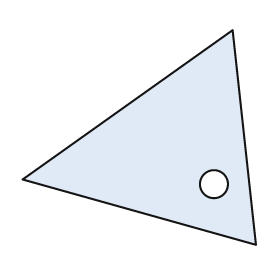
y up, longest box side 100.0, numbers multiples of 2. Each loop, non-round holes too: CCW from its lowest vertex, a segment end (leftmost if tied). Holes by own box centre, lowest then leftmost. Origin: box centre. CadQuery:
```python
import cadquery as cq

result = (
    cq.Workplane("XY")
    .moveTo(50.0, -46.0)
    .lineTo(40.0, 46.0)
    .lineTo(-50.0, -18.0)
    .close()
    .moveTo(32.0, -20.0)
    .circle(6.0)
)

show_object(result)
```